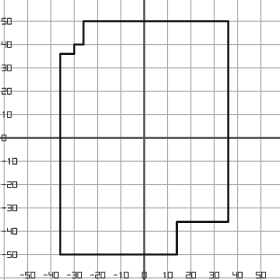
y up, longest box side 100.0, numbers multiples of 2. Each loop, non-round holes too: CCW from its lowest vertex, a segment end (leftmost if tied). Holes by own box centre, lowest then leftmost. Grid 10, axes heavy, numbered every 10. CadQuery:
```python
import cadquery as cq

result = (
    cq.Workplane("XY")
    .moveTo(-36.0, -50.0)
    .lineTo(14.0, -50.0)
    .lineTo(14.0, -36.0)
    .lineTo(36.0, -36.0)
    .lineTo(36.0, 50.0)
    .lineTo(-26.0, 50.0)
    .lineTo(-26.0, 40.0)
    .lineTo(-30.0, 40.0)
    .lineTo(-30.0, 36.0)
    .lineTo(-36.0, 36.0)
    .close()
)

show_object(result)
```